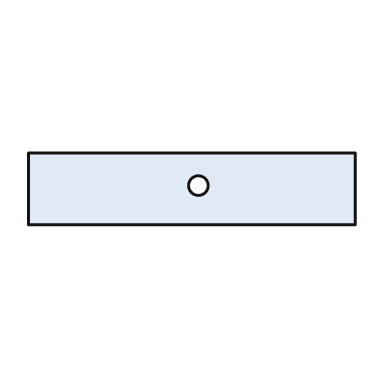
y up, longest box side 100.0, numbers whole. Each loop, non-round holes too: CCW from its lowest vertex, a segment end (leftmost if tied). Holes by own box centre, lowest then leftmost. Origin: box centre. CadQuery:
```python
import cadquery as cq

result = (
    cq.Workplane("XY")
    .moveTo(-50.0, -11.0)
    .lineTo(50.0, -11.0)
    .lineTo(50.0, 11.0)
    .lineTo(-50.0, 11.0)
    .close()
    .moveTo(2.0, 1.0)
    .circle(3.0)
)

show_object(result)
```